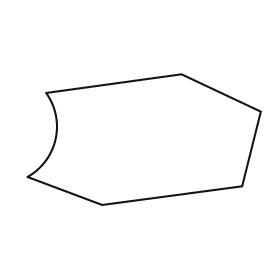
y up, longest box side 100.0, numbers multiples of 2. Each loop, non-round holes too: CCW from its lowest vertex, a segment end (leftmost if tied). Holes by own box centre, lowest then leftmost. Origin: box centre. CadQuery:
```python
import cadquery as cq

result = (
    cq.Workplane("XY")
    .moveTo(-18.0, -28.0)
    .lineTo(42.0, -20.0)
    .lineTo(50.0, 12.0)
    .lineTo(16.0, 28.0)
    .lineTo(-42.0, 20.0)
    .threePointArc((-38.0, 0.0), (-50.0, -16.0))
    .close()
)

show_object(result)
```